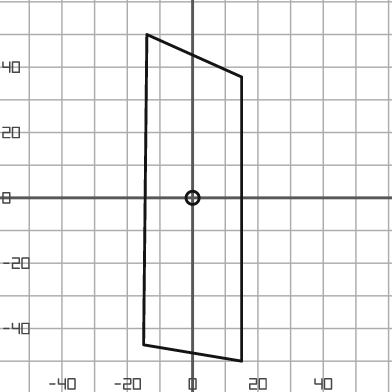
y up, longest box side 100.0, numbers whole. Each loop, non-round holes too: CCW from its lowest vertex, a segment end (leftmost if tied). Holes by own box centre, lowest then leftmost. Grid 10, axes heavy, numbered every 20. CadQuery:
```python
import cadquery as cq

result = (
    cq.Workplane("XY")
    .moveTo(15.0, -50.0)
    .lineTo(15.0, 37.0)
    .lineTo(-14.0, 50.0)
    .lineTo(-15.0, -45.0)
    .close()
    .moveTo(0.0, 0.0)
    .circle(2.0)
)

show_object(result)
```